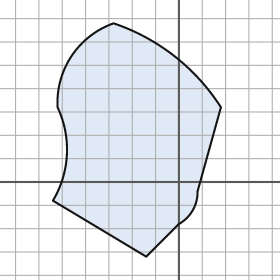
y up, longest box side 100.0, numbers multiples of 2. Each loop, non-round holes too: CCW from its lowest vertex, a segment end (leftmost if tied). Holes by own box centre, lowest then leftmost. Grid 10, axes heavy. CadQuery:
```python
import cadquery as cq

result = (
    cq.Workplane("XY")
    .moveTo(-14.0, -32.0)
    .lineTo(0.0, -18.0)
    .threePointArc((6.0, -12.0), (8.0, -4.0))
    .lineTo(18.0, 32.0)
    .threePointArc((-2.0, 54.0), (-28.0, 68.0))
    .threePointArc((-46.0, 54.0), (-52.0, 32.0))
    .threePointArc((-48.0, 12.0), (-54.0, -8.0))
    .close()
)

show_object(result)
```